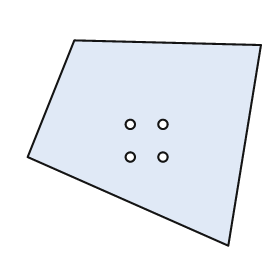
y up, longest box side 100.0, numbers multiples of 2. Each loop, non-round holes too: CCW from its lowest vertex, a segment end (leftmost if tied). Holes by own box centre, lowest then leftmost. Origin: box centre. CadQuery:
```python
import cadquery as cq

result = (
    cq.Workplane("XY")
    .moveTo(36.0, -44.0)
    .lineTo(50.0, 42.0)
    .lineTo(-30.0, 44.0)
    .lineTo(-50.0, -6.0)
    .close()
    .moveTo(-6.0, -6.0)
    .circle(2.0)
    .moveTo(8.0, -6.0)
    .circle(2.0)
    .moveTo(-6.0, 8.0)
    .circle(2.0)
    .moveTo(8.0, 8.0)
    .circle(2.0)
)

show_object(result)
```